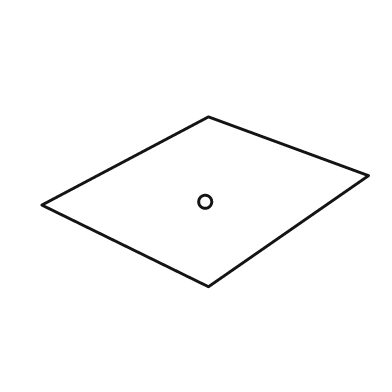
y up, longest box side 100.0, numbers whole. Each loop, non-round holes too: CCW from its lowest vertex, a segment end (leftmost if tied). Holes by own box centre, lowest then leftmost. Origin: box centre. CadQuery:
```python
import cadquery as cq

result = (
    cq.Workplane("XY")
    .moveTo(1.0, -26.0)
    .lineTo(50.0, 8.0)
    .lineTo(1.0, 26.0)
    .lineTo(-50.0, -1.0)
    .close()
    .moveTo(0.0, 0.0)
    .circle(2.0)
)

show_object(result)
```